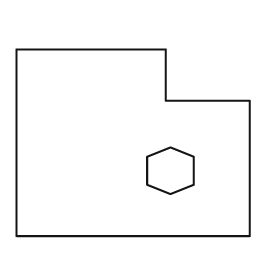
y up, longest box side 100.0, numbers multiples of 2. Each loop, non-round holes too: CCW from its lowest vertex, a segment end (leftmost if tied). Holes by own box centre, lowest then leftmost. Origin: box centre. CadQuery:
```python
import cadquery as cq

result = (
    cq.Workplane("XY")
    .moveTo(-50.0, -40.0)
    .lineTo(50.0, -40.0)
    .lineTo(50.0, 18.0)
    .lineTo(14.0, 18.0)
    .lineTo(14.0, 40.0)
    .lineTo(-50.0, 40.0)
    .close()
    .moveTo(16.0, -22.0)
    .lineTo(26.0, -18.0)
    .lineTo(26.0, -6.0)
    .lineTo(16.0, -2.0)
    .lineTo(6.0, -6.0)
    .lineTo(6.0, -18.0)
    .close()
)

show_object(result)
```